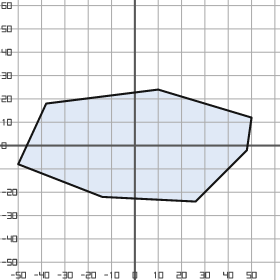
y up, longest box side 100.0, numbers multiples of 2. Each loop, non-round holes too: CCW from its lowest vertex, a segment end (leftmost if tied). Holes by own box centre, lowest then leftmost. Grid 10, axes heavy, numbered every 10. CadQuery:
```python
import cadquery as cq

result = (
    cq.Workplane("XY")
    .moveTo(26.0, -24.0)
    .lineTo(48.0, -2.0)
    .lineTo(50.0, 12.0)
    .lineTo(10.0, 24.0)
    .lineTo(-38.0, 18.0)
    .lineTo(-50.0, -8.0)
    .lineTo(-14.0, -22.0)
    .close()
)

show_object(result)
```